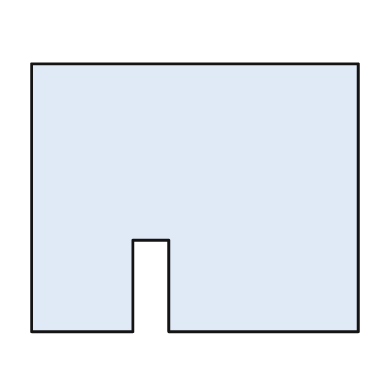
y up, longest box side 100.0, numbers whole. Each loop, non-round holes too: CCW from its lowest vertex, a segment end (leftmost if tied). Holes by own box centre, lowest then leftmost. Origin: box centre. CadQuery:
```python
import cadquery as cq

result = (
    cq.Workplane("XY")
    .moveTo(-50.0, -41.0)
    .lineTo(-19.0, -41.0)
    .lineTo(-19.0, -13.0)
    .lineTo(-8.0, -13.0)
    .lineTo(-8.0, -41.0)
    .lineTo(50.0, -41.0)
    .lineTo(50.0, 41.0)
    .lineTo(-50.0, 41.0)
    .close()
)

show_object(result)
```